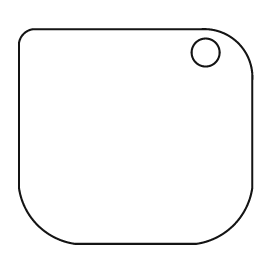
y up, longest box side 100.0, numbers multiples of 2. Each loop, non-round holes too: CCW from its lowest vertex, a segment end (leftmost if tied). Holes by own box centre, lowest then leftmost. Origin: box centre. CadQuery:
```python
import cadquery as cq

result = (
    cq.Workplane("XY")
    .moveTo(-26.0, -46.0)
    .lineTo(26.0, -46.0)
    .threePointArc((42.0, -38.0), (50.0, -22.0))
    .lineTo(50.0, 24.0)
    .threePointArc((44.0, 40.0), (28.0, 46.0))
    .lineTo(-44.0, 46.0)
    .threePointArc((-48.0, 44.0), (-50.0, 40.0))
    .lineTo(-50.0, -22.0)
    .threePointArc((-42.0, -38.0), (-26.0, -46.0))
    .close()
    .moveTo(30.0, 36.0)
    .circle(6.0)
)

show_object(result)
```